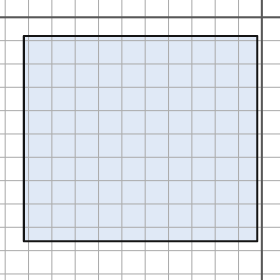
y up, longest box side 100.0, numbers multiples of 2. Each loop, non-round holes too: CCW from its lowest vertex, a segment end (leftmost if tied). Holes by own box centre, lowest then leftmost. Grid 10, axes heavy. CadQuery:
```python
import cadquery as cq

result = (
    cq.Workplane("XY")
    .moveTo(-102.0, -96.0)
    .lineTo(-2.0, -96.0)
    .lineTo(-2.0, -8.0)
    .lineTo(-102.0, -8.0)
    .close()
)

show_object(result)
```